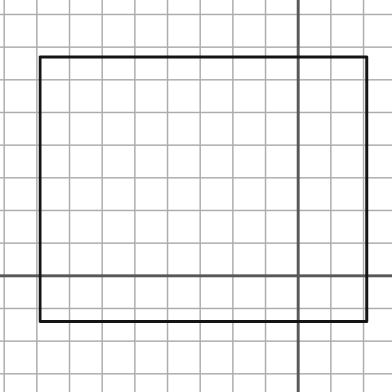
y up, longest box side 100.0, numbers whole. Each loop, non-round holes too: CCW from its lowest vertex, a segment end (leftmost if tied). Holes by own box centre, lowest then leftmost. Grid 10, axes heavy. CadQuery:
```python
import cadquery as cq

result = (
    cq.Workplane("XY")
    .moveTo(-79.0, -14.0)
    .lineTo(21.0, -14.0)
    .lineTo(21.0, 67.0)
    .lineTo(-79.0, 67.0)
    .close()
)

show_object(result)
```